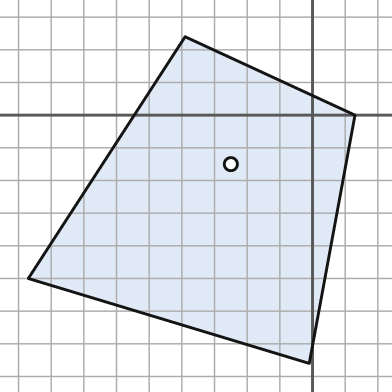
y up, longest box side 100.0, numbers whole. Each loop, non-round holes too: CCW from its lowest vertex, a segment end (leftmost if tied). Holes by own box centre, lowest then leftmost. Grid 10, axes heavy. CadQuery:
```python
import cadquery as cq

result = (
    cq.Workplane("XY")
    .moveTo(-1.0, -76.0)
    .lineTo(13.0, 0.0)
    .lineTo(-39.0, 24.0)
    .lineTo(-87.0, -50.0)
    .close()
    .moveTo(-25.0, -15.0)
    .circle(2.0)
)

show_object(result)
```